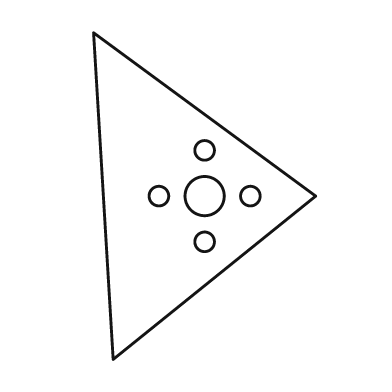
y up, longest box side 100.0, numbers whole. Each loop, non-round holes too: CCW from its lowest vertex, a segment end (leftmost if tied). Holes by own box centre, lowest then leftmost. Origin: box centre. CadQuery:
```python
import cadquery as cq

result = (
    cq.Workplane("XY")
    .moveTo(-28.0, -50.0)
    .lineTo(34.0, 0.0)
    .lineTo(-34.0, 50.0)
    .close()
    .moveTo(0.0, -14.0)
    .circle(3.0)
    .moveTo(-14.0, 0.0)
    .circle(3.0)
    .moveTo(0.0, 0.0)
    .circle(6.0)
    .moveTo(14.0, 0.0)
    .circle(3.0)
    .moveTo(0.0, 14.0)
    .circle(3.0)
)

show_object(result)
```